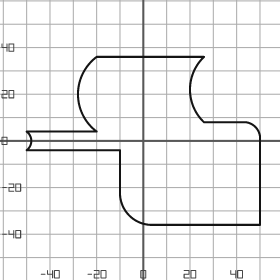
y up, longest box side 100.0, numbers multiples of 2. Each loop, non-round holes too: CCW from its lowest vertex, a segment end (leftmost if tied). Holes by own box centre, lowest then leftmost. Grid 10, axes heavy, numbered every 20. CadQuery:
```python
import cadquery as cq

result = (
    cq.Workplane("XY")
    .moveTo(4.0, -36.0)
    .lineTo(50.0, -36.0)
    .lineTo(50.0, 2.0)
    .threePointArc((48.0, 6.0), (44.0, 8.0))
    .lineTo(26.0, 8.0)
    .threePointArc((20.0, 22.0), (26.0, 36.0))
    .lineTo(-20.0, 36.0)
    .threePointArc((-28.0, 20.0), (-20.0, 4.0))
    .lineTo(-50.0, 4.0)
    .threePointArc((-48.0, 0.0), (-50.0, -4.0))
    .lineTo(-10.0, -4.0)
    .lineTo(-10.0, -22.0)
    .threePointArc((-6.0, -32.0), (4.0, -36.0))
    .close()
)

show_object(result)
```